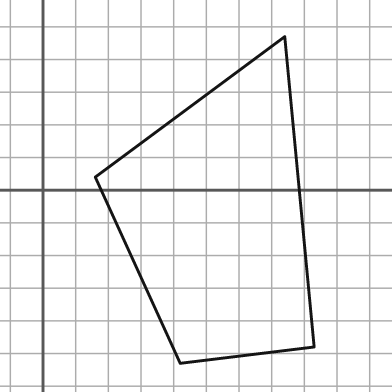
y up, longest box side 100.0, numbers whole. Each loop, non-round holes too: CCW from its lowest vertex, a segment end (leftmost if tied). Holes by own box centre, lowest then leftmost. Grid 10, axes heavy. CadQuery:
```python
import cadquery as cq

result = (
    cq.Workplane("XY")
    .moveTo(42.0, -53.0)
    .lineTo(83.0, -48.0)
    .lineTo(74.0, 47.0)
    .lineTo(16.0, 4.0)
    .close()
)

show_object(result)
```